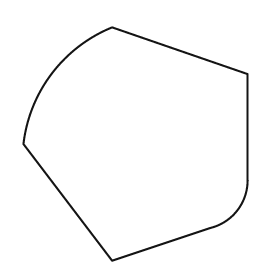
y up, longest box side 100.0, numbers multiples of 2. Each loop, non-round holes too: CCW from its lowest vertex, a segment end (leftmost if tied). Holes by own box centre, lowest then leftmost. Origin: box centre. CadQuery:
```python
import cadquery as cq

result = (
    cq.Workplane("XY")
    .moveTo(-10.0, -50.0)
    .lineTo(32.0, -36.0)
    .threePointArc((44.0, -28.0), (48.0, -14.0))
    .lineTo(48.0, 30.0)
    .lineTo(-10.0, 50.0)
    .threePointArc((-36.0, 30.0), (-48.0, 0.0))
    .close()
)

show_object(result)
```